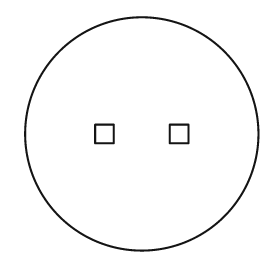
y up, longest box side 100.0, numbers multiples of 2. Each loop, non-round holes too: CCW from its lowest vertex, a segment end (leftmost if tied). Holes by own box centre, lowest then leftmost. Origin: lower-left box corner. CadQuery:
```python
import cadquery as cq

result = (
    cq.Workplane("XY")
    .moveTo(50.0, 50.0)
    .circle(50.0)
    .moveTo(30.0, 46.0)
    .lineTo(38.0, 46.0)
    .lineTo(38.0, 54.0)
    .lineTo(30.0, 54.0)
    .close()
    .moveTo(62.0, 46.0)
    .lineTo(70.0, 46.0)
    .lineTo(70.0, 54.0)
    .lineTo(62.0, 54.0)
    .close()
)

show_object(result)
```